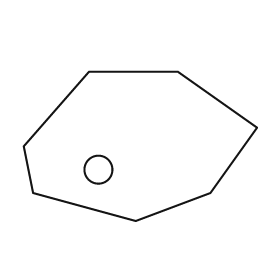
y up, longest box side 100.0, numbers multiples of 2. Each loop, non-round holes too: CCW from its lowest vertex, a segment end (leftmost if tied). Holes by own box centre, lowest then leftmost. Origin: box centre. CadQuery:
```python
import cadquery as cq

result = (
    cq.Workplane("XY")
    .moveTo(-2.0, -32.0)
    .lineTo(30.0, -20.0)
    .lineTo(50.0, 8.0)
    .lineTo(16.0, 32.0)
    .lineTo(-22.0, 32.0)
    .lineTo(-50.0, 0.0)
    .lineTo(-46.0, -20.0)
    .close()
    .moveTo(-18.0, -10.0)
    .circle(6.0)
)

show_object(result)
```